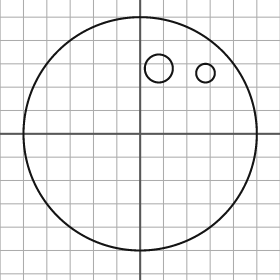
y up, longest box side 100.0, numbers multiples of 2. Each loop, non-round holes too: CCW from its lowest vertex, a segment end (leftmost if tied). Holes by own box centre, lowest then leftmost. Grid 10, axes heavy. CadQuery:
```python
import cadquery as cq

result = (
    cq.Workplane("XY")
    .moveTo(0.0, 0.0)
    .circle(50.0)
    .moveTo(28.0, 26.0)
    .circle(4.0)
    .moveTo(8.0, 28.0)
    .circle(6.0)
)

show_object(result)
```